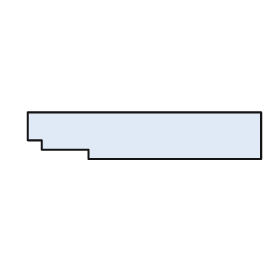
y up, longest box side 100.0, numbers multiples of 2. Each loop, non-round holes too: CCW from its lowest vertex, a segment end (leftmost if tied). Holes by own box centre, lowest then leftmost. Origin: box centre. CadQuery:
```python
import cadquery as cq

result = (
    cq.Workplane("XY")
    .moveTo(-24.0, -10.0)
    .lineTo(50.0, -10.0)
    .lineTo(50.0, 10.0)
    .lineTo(-50.0, 10.0)
    .lineTo(-50.0, -2.0)
    .lineTo(-44.0, -2.0)
    .lineTo(-44.0, -6.0)
    .lineTo(-24.0, -6.0)
    .close()
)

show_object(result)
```